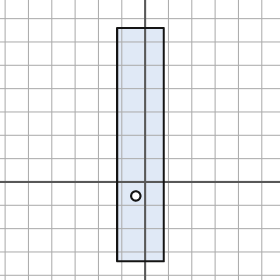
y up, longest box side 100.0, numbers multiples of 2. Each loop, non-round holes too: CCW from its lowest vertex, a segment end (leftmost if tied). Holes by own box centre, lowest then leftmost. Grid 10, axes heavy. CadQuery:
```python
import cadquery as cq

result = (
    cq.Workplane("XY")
    .moveTo(-12.0, -34.0)
    .lineTo(8.0, -34.0)
    .lineTo(8.0, 66.0)
    .lineTo(-12.0, 66.0)
    .close()
    .moveTo(-4.0, -6.0)
    .circle(2.0)
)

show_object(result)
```